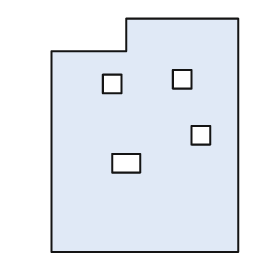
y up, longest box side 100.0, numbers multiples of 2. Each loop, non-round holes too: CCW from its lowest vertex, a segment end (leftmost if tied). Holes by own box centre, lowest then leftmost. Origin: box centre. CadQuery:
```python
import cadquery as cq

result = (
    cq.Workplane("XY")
    .moveTo(-40.0, -50.0)
    .lineTo(40.0, -50.0)
    .lineTo(40.0, 50.0)
    .lineTo(-8.0, 50.0)
    .lineTo(-8.0, 36.0)
    .lineTo(-40.0, 36.0)
    .close()
    .moveTo(-14.0, -16.0)
    .lineTo(-2.0, -16.0)
    .lineTo(-2.0, -8.0)
    .lineTo(-14.0, -8.0)
    .close()
    .moveTo(20.0, -4.0)
    .lineTo(28.0, -4.0)
    .lineTo(28.0, 4.0)
    .lineTo(20.0, 4.0)
    .close()
    .moveTo(-18.0, 18.0)
    .lineTo(-10.0, 18.0)
    .lineTo(-10.0, 26.0)
    .lineTo(-18.0, 26.0)
    .close()
    .moveTo(12.0, 20.0)
    .lineTo(20.0, 20.0)
    .lineTo(20.0, 28.0)
    .lineTo(12.0, 28.0)
    .close()
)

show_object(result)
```